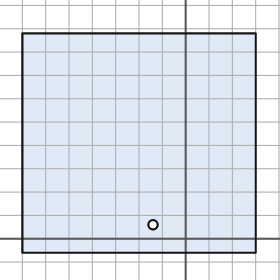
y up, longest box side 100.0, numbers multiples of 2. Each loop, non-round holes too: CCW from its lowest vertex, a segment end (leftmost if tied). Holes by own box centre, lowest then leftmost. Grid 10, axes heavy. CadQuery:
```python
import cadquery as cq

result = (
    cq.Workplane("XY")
    .moveTo(-70.0, -6.0)
    .lineTo(30.0, -6.0)
    .lineTo(30.0, 88.0)
    .lineTo(-70.0, 88.0)
    .close()
    .moveTo(-14.0, 6.0)
    .circle(2.0)
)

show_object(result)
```